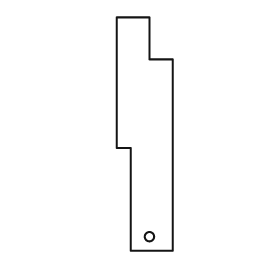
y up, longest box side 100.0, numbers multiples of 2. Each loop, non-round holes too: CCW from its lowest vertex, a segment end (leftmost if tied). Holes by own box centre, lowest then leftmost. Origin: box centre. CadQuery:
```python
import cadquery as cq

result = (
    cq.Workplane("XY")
    .moveTo(-6.0, -50.0)
    .lineTo(12.0, -50.0)
    .lineTo(12.0, 32.0)
    .lineTo(2.0, 32.0)
    .lineTo(2.0, 50.0)
    .lineTo(-12.0, 50.0)
    .lineTo(-12.0, -6.0)
    .lineTo(-6.0, -6.0)
    .close()
    .moveTo(2.0, -44.0)
    .circle(2.0)
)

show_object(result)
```